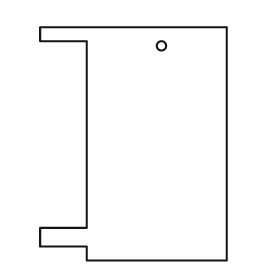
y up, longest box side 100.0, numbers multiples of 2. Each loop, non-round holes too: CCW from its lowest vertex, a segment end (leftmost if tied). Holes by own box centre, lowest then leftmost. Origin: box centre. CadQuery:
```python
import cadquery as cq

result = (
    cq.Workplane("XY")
    .moveTo(-20.0, -50.0)
    .lineTo(40.0, -50.0)
    .lineTo(40.0, 50.0)
    .lineTo(-40.0, 50.0)
    .lineTo(-40.0, 44.0)
    .lineTo(-20.0, 44.0)
    .lineTo(-20.0, -36.0)
    .lineTo(-40.0, -36.0)
    .lineTo(-40.0, -44.0)
    .lineTo(-20.0, -44.0)
    .close()
    .moveTo(12.0, 42.0)
    .circle(2.0)
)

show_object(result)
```